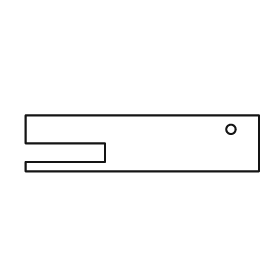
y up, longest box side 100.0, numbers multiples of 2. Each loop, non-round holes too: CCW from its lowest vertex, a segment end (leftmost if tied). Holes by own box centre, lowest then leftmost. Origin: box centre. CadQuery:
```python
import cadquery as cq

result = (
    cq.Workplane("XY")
    .moveTo(-50.0, -12.0)
    .lineTo(50.0, -12.0)
    .lineTo(50.0, 12.0)
    .lineTo(-50.0, 12.0)
    .lineTo(-50.0, 0.0)
    .lineTo(-16.0, 0.0)
    .lineTo(-16.0, -8.0)
    .lineTo(-50.0, -8.0)
    .close()
    .moveTo(38.0, 6.0)
    .circle(2.0)
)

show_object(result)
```